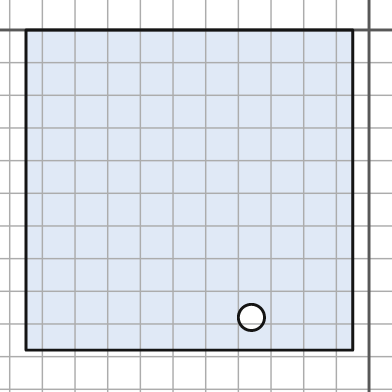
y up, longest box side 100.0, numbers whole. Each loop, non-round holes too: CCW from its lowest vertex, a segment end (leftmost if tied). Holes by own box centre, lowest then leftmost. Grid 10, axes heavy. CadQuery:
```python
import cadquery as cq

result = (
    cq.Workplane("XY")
    .moveTo(-105.0, -98.0)
    .lineTo(-5.0, -98.0)
    .lineTo(-5.0, 0.0)
    .lineTo(-105.0, 0.0)
    .close()
    .moveTo(-36.0, -88.0)
    .circle(4.0)
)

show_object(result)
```